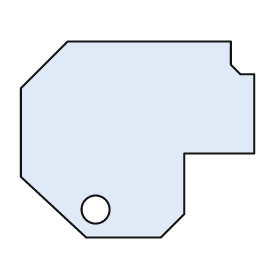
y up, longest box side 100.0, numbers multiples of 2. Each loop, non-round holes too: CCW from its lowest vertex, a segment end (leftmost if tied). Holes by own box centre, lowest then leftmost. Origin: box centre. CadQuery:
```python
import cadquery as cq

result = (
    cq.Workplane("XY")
    .moveTo(-22.0, -42.0)
    .lineTo(10.0, -42.0)
    .lineTo(20.0, -32.0)
    .lineTo(20.0, -6.0)
    .lineTo(50.0, -6.0)
    .lineTo(50.0, 28.0)
    .lineTo(44.0, 28.0)
    .lineTo(40.0, 32.0)
    .lineTo(40.0, 42.0)
    .lineTo(-30.0, 42.0)
    .lineTo(-50.0, 22.0)
    .lineTo(-50.0, -16.0)
    .close()
    .moveTo(-18.0, -30.0)
    .circle(6.0)
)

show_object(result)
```